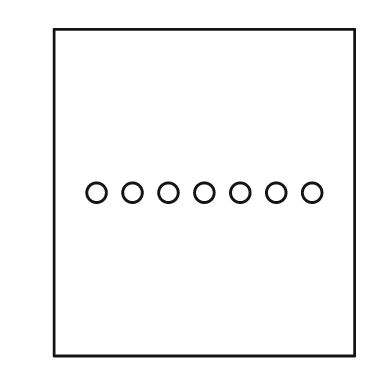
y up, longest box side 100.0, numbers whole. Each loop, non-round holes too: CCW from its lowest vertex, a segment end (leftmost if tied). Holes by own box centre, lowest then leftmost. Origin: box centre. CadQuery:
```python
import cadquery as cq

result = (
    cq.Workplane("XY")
    .moveTo(-46.0, -50.0)
    .lineTo(46.0, -50.0)
    .lineTo(46.0, 50.0)
    .lineTo(-46.0, 50.0)
    .close()
    .moveTo(-33.0, 0.0)
    .circle(3.0)
    .moveTo(-22.0, 0.0)
    .circle(3.0)
    .moveTo(-11.0, 0.0)
    .circle(3.0)
    .moveTo(0.0, 0.0)
    .circle(3.0)
    .moveTo(11.0, 0.0)
    .circle(3.0)
    .moveTo(22.0, 0.0)
    .circle(3.0)
    .moveTo(33.0, 0.0)
    .circle(3.0)
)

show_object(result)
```